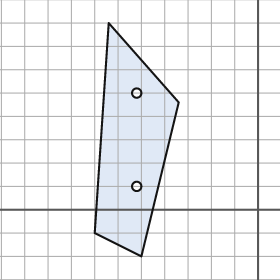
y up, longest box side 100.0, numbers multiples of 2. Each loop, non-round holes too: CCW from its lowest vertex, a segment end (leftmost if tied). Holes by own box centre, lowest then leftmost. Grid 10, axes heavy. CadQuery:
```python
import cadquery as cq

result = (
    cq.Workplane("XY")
    .moveTo(-50.0, -20.0)
    .lineTo(-34.0, 46.0)
    .lineTo(-64.0, 80.0)
    .lineTo(-70.0, -10.0)
    .close()
    .moveTo(-52.0, 10.0)
    .circle(2.0)
    .moveTo(-52.0, 50.0)
    .circle(2.0)
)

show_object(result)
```